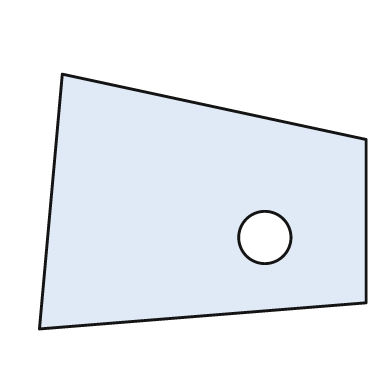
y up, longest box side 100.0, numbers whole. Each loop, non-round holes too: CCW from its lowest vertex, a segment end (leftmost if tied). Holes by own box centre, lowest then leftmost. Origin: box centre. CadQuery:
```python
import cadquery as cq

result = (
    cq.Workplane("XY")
    .moveTo(-50.0, -39.0)
    .lineTo(50.0, -31.0)
    .lineTo(50.0, 19.0)
    .lineTo(-43.0, 39.0)
    .close()
    .moveTo(19.0, -11.0)
    .circle(8.0)
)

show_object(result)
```